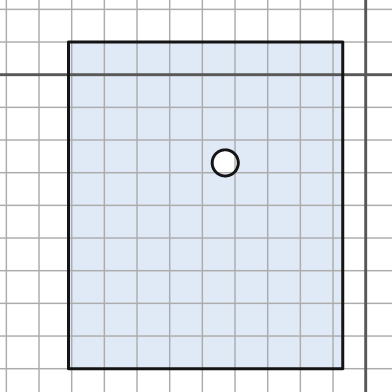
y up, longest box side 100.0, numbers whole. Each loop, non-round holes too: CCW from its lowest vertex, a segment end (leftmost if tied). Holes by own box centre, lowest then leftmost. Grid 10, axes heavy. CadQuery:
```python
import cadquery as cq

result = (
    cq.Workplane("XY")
    .moveTo(-91.0, -90.0)
    .lineTo(-7.0, -90.0)
    .lineTo(-7.0, 10.0)
    .lineTo(-91.0, 10.0)
    .close()
    .moveTo(-43.0, -27.0)
    .circle(4.0)
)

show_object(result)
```